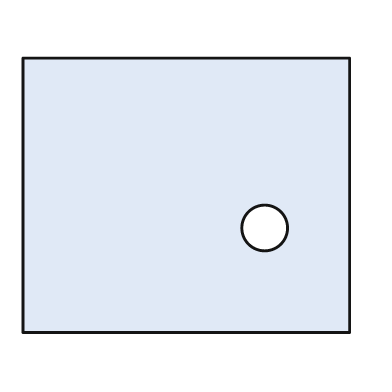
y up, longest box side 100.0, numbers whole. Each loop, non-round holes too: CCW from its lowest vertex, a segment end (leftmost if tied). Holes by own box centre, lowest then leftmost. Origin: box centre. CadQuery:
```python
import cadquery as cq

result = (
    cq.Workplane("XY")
    .moveTo(-50.0, -42.0)
    .lineTo(50.0, -42.0)
    .lineTo(50.0, 42.0)
    .lineTo(-50.0, 42.0)
    .close()
    .moveTo(24.0, -10.0)
    .circle(7.0)
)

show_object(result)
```